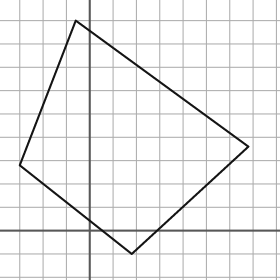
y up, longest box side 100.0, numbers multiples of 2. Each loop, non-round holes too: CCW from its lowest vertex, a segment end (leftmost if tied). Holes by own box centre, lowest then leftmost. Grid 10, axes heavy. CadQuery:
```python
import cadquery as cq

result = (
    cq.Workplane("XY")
    .moveTo(18.0, -10.0)
    .lineTo(68.0, 36.0)
    .lineTo(-6.0, 90.0)
    .lineTo(-30.0, 28.0)
    .close()
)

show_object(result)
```